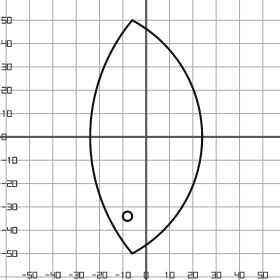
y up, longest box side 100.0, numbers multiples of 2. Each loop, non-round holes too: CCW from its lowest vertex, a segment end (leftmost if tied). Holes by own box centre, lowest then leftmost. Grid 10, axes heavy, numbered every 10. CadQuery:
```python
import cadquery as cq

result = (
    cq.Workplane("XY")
    .moveTo(-6.0, -50.0)
    .threePointArc((24.0, 0.0), (-6.0, 50.0))
    .threePointArc((-24.0, 0.0), (-6.0, -50.0))
    .close()
    .moveTo(-8.0, -34.0)
    .circle(2.0)
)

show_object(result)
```